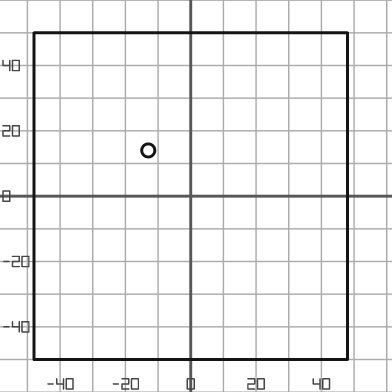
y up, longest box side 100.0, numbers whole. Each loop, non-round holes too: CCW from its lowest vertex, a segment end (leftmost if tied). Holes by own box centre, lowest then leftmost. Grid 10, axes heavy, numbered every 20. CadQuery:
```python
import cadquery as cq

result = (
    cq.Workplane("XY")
    .moveTo(-48.0, -50.0)
    .lineTo(48.0, -50.0)
    .lineTo(48.0, 50.0)
    .lineTo(-48.0, 50.0)
    .close()
    .moveTo(-13.0, 14.0)
    .circle(2.0)
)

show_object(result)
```